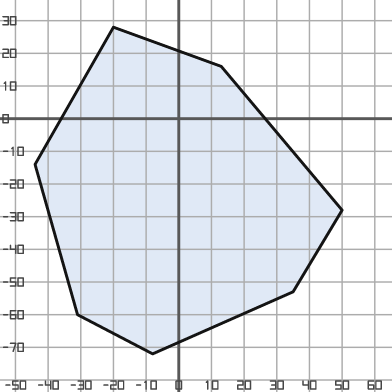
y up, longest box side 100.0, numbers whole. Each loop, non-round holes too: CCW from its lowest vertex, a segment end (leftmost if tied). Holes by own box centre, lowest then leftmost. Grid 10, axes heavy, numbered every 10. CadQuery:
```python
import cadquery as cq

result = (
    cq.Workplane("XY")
    .moveTo(-8.0, -72.0)
    .lineTo(35.0, -53.0)
    .lineTo(50.0, -28.0)
    .lineTo(13.0, 16.0)
    .lineTo(-20.0, 28.0)
    .lineTo(-44.0, -14.0)
    .lineTo(-31.0, -60.0)
    .close()
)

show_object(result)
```